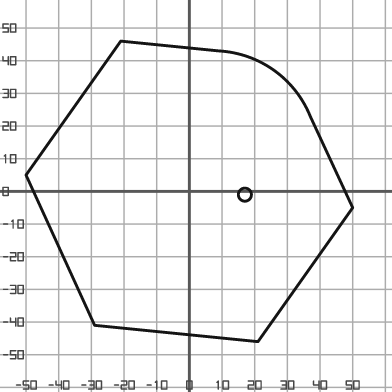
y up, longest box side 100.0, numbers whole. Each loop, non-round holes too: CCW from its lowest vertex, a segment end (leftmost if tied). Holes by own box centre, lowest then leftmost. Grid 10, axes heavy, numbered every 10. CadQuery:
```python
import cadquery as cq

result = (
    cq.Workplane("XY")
    .moveTo(21.0, -46.0)
    .lineTo(50.0, -5.0)
    .lineTo(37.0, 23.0)
    .threePointArc((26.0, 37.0), (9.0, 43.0))
    .lineTo(-21.0, 46.0)
    .lineTo(-50.0, 5.0)
    .lineTo(-29.0, -41.0)
    .close()
    .moveTo(17.0, -1.0)
    .circle(2.0)
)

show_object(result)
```